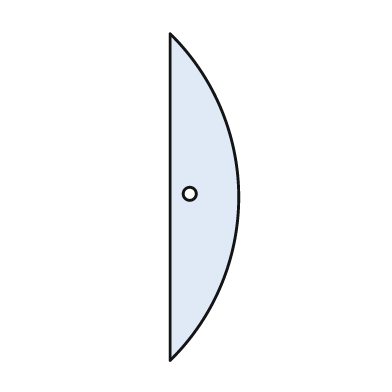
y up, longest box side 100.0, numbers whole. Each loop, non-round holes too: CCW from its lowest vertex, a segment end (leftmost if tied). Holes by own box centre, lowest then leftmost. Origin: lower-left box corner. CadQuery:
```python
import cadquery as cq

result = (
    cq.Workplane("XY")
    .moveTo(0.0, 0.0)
    .threePointArc((21.0, 50.0), (0.0, 100.0))
    .close()
    .moveTo(6.0, 51.0)
    .circle(2.0)
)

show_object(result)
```